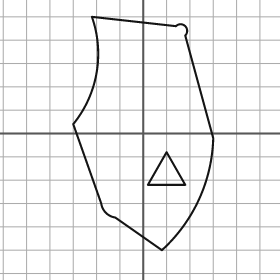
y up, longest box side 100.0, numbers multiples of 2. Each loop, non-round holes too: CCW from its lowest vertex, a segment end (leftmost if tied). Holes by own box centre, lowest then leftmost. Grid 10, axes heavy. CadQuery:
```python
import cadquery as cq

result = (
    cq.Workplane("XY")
    .moveTo(8.0, -50.0)
    .threePointArc((24.0, -28.0), (30.0, -2.0))
    .lineTo(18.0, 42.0)
    .threePointArc((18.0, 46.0), (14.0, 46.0))
    .lineTo(-22.0, 50.0)
    .threePointArc((-20.0, 26.0), (-30.0, 4.0))
    .lineTo(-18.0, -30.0)
    .threePointArc((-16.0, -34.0), (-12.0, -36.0))
    .close()
    .moveTo(2.0, -22.0)
    .lineTo(18.0, -22.0)
    .lineTo(10.0, -8.0)
    .close()
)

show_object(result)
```